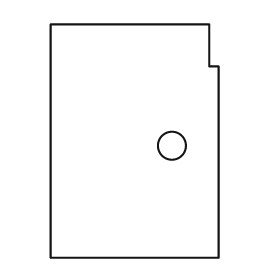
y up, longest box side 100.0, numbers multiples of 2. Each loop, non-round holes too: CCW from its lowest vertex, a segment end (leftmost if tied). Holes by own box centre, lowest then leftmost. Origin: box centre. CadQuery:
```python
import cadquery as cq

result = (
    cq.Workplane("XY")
    .moveTo(-36.0, -50.0)
    .lineTo(36.0, -50.0)
    .lineTo(36.0, 32.0)
    .lineTo(32.0, 32.0)
    .lineTo(32.0, 50.0)
    .lineTo(-36.0, 50.0)
    .close()
    .moveTo(16.0, -2.0)
    .circle(6.0)
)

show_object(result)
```